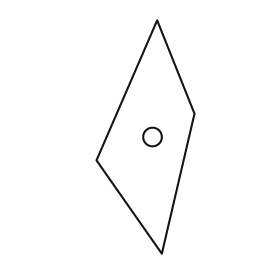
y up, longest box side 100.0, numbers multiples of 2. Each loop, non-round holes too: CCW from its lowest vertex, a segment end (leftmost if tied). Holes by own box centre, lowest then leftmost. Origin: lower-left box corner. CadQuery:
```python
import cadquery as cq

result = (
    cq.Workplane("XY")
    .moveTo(28.0, 0.0)
    .lineTo(42.0, 60.0)
    .lineTo(26.0, 100.0)
    .lineTo(0.0, 40.0)
    .close()
    .moveTo(24.0, 50.0)
    .circle(4.0)
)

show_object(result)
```